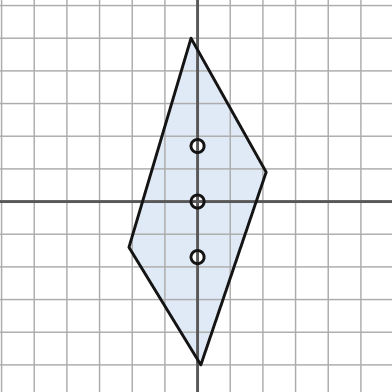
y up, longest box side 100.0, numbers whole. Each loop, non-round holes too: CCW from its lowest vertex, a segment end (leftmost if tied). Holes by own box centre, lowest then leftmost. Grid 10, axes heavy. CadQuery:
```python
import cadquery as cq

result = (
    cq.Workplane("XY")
    .moveTo(1.0, -50.0)
    .lineTo(21.0, 9.0)
    .lineTo(-2.0, 50.0)
    .lineTo(-21.0, -14.0)
    .close()
    .moveTo(0.0, -17.0)
    .circle(2.0)
    .moveTo(0.0, 0.0)
    .circle(2.0)
    .moveTo(0.0, 17.0)
    .circle(2.0)
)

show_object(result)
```